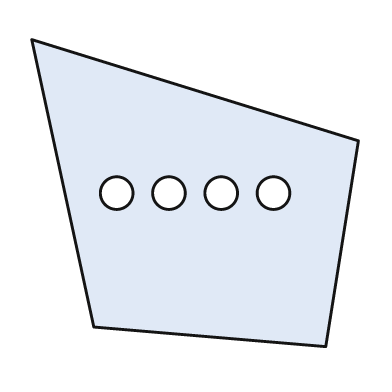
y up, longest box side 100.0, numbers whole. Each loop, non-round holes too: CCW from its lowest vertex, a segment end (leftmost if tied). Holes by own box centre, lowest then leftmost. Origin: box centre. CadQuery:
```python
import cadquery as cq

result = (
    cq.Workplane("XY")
    .moveTo(40.0, -47.0)
    .lineTo(50.0, 16.0)
    .lineTo(-50.0, 47.0)
    .lineTo(-31.0, -41.0)
    .close()
    .moveTo(-24.0, 0.0)
    .circle(5.0)
    .moveTo(-8.0, 0.0)
    .circle(5.0)
    .moveTo(8.0, 0.0)
    .circle(5.0)
    .moveTo(24.0, 0.0)
    .circle(5.0)
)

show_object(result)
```